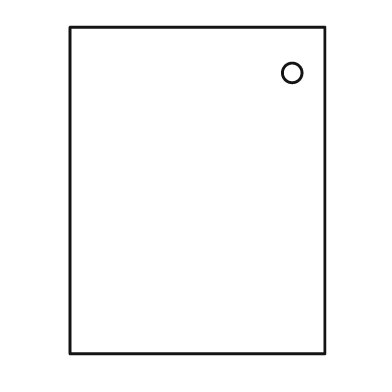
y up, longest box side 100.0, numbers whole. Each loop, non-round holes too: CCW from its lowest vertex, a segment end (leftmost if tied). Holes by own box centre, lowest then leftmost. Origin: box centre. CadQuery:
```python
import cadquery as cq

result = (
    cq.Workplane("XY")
    .moveTo(-39.0, -50.0)
    .lineTo(39.0, -50.0)
    .lineTo(39.0, 50.0)
    .lineTo(-39.0, 50.0)
    .close()
    .moveTo(29.0, 36.0)
    .circle(3.0)
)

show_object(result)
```